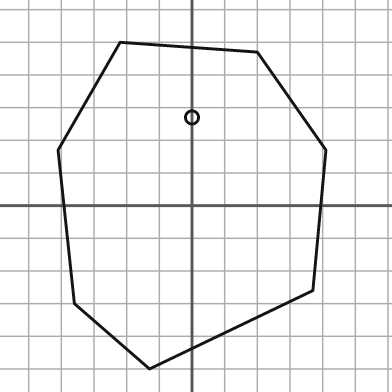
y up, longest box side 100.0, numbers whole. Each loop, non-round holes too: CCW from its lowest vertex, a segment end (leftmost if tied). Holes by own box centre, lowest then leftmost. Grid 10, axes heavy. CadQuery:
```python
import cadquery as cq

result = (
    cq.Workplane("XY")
    .moveTo(-13.0, -50.0)
    .lineTo(37.0, -26.0)
    .lineTo(41.0, 17.0)
    .lineTo(20.0, 47.0)
    .lineTo(-22.0, 50.0)
    .lineTo(-41.0, 17.0)
    .lineTo(-36.0, -30.0)
    .close()
    .moveTo(0.0, 27.0)
    .circle(2.0)
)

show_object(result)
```